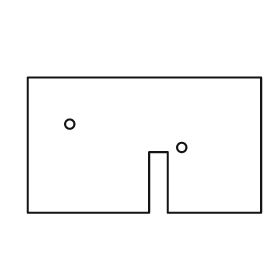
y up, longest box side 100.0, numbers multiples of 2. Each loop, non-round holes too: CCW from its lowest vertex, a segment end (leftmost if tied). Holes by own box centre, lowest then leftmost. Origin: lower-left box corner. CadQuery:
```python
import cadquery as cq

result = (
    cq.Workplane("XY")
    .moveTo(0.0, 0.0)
    .lineTo(52.0, 0.0)
    .lineTo(52.0, 26.0)
    .lineTo(60.0, 26.0)
    .lineTo(60.0, 0.0)
    .lineTo(100.0, 0.0)
    .lineTo(100.0, 58.0)
    .lineTo(0.0, 58.0)
    .close()
    .moveTo(66.0, 28.0)
    .circle(2.0)
    .moveTo(18.0, 38.0)
    .circle(2.0)
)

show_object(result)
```